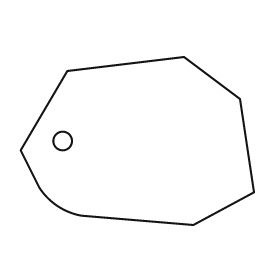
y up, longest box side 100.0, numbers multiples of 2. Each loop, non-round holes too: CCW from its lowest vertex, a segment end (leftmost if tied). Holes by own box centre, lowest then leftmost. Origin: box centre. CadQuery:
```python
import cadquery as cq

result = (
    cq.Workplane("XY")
    .moveTo(24.0, -36.0)
    .lineTo(50.0, -22.0)
    .lineTo(44.0, 18.0)
    .lineTo(20.0, 36.0)
    .lineTo(-30.0, 30.0)
    .lineTo(-50.0, -4.0)
    .lineTo(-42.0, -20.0)
    .threePointArc((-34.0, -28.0), (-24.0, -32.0))
    .close()
    .moveTo(-32.0, 0.0)
    .circle(4.0)
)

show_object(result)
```